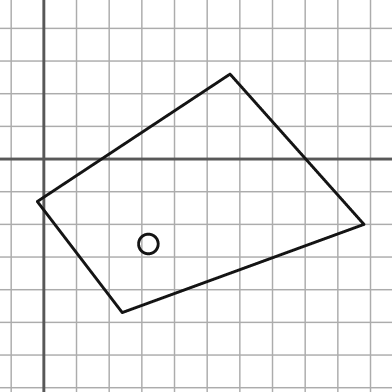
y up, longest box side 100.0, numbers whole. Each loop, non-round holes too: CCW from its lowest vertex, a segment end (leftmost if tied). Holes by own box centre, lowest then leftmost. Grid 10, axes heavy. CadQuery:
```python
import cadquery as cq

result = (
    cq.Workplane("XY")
    .moveTo(24.0, -47.0)
    .lineTo(98.0, -20.0)
    .lineTo(57.0, 26.0)
    .lineTo(-2.0, -13.0)
    .close()
    .moveTo(32.0, -26.0)
    .circle(3.0)
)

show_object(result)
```